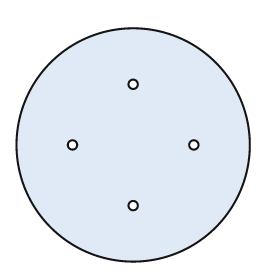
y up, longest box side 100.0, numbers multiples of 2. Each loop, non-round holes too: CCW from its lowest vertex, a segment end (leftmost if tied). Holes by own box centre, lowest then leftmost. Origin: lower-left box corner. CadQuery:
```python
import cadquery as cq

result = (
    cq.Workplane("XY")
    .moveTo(50.0, 50.0)
    .circle(50.0)
    .moveTo(50.0, 24.0)
    .circle(2.0)
    .moveTo(24.0, 50.0)
    .circle(2.0)
    .moveTo(76.0, 50.0)
    .circle(2.0)
    .moveTo(50.0, 76.0)
    .circle(2.0)
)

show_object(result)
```